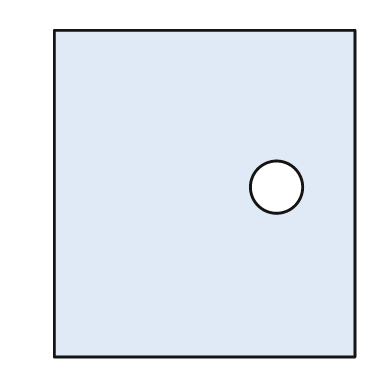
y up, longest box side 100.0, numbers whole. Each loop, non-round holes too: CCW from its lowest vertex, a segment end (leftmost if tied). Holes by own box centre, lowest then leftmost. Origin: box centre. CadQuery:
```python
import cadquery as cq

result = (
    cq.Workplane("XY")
    .moveTo(-46.0, -50.0)
    .lineTo(46.0, -50.0)
    .lineTo(46.0, 50.0)
    .lineTo(-46.0, 50.0)
    .close()
    .moveTo(22.0, 2.0)
    .circle(8.0)
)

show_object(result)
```